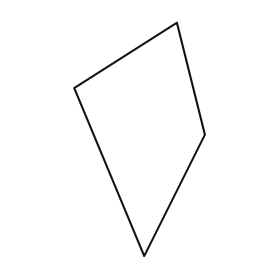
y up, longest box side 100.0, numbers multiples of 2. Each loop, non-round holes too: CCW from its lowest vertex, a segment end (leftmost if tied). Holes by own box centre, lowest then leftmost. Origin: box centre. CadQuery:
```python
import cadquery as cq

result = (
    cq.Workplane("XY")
    .moveTo(2.0, -50.0)
    .lineTo(28.0, 2.0)
    .lineTo(16.0, 50.0)
    .lineTo(-28.0, 22.0)
    .close()
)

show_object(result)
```